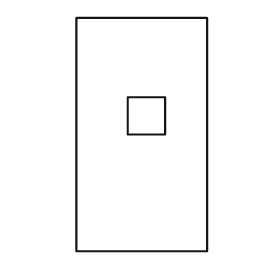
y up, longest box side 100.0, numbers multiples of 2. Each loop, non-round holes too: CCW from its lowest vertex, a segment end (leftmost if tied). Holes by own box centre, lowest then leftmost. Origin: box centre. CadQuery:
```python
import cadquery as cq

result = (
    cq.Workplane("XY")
    .moveTo(-28.0, -50.0)
    .lineTo(28.0, -50.0)
    .lineTo(28.0, 50.0)
    .lineTo(-28.0, 50.0)
    .close()
    .moveTo(-6.0, 0.0)
    .lineTo(10.0, 0.0)
    .lineTo(10.0, 16.0)
    .lineTo(-6.0, 16.0)
    .close()
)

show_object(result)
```